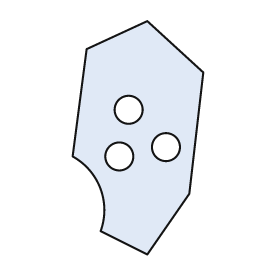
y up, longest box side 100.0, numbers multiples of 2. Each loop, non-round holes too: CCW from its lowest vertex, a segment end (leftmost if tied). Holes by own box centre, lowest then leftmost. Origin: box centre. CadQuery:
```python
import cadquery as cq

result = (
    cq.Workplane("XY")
    .moveTo(4.0, -50.0)
    .lineTo(22.0, -24.0)
    .lineTo(28.0, 28.0)
    .lineTo(4.0, 50.0)
    .lineTo(-22.0, 38.0)
    .lineTo(-28.0, -8.0)
    .threePointArc((-16.0, -22.0), (-16.0, -40.0))
    .close()
    .moveTo(-8.0, -8.0)
    .circle(6.0)
    .moveTo(12.0, -4.0)
    .circle(6.0)
    .moveTo(-4.0, 12.0)
    .circle(6.0)
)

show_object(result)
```